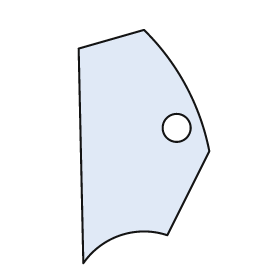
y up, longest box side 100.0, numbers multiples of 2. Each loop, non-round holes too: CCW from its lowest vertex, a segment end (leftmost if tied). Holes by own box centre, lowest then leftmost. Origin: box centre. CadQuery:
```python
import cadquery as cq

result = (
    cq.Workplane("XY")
    .moveTo(-26.0, -50.0)
    .threePointArc((-10.0, -38.0), (10.0, -38.0))
    .lineTo(28.0, -2.0)
    .threePointArc((18.0, 26.0), (0.0, 50.0))
    .lineTo(-28.0, 42.0)
    .close()
    .moveTo(14.0, 8.0)
    .circle(6.0)
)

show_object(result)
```